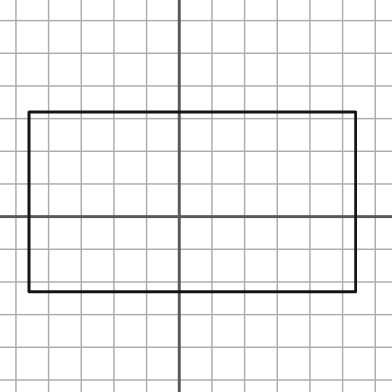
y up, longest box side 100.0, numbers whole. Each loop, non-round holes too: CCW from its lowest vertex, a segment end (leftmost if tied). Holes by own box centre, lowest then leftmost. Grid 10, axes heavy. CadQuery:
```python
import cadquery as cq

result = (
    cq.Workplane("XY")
    .moveTo(-46.0, -23.0)
    .lineTo(54.0, -23.0)
    .lineTo(54.0, 32.0)
    .lineTo(-46.0, 32.0)
    .close()
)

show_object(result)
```